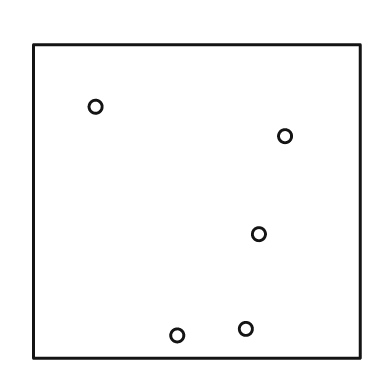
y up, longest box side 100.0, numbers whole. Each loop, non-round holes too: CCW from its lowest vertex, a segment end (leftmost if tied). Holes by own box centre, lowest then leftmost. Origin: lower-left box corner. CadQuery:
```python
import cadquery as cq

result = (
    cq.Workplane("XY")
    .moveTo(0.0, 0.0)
    .lineTo(100.0, 0.0)
    .lineTo(100.0, 96.0)
    .lineTo(0.0, 96.0)
    .close()
    .moveTo(44.0, 7.0)
    .circle(2.0)
    .moveTo(65.0, 9.0)
    .circle(2.0)
    .moveTo(69.0, 38.0)
    .circle(2.0)
    .moveTo(77.0, 68.0)
    .circle(2.0)
    .moveTo(19.0, 77.0)
    .circle(2.0)
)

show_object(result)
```